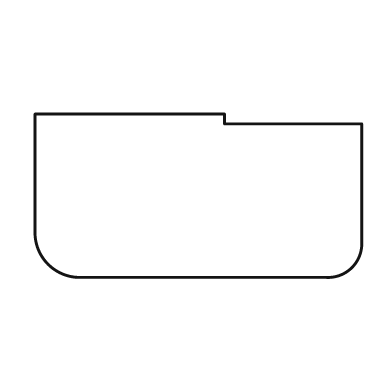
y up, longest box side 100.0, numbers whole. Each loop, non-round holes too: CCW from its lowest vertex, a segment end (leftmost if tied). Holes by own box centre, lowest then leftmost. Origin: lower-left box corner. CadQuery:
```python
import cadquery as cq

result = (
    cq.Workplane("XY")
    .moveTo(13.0, 0.0)
    .lineTo(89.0, 0.0)
    .threePointArc((97.0, 3.0), (100.0, 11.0))
    .lineTo(100.0, 47.0)
    .lineTo(58.0, 47.0)
    .lineTo(58.0, 50.0)
    .lineTo(0.0, 50.0)
    .lineTo(0.0, 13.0)
    .threePointArc((4.0, 4.0), (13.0, 0.0))
    .close()
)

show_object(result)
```